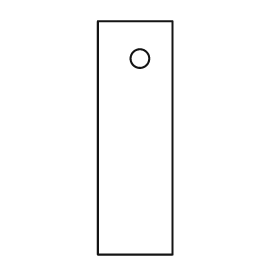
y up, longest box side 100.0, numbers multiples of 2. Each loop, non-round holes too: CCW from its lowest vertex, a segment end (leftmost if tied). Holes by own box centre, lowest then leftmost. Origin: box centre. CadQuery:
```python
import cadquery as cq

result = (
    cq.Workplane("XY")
    .moveTo(-16.0, -50.0)
    .lineTo(16.0, -50.0)
    .lineTo(16.0, 50.0)
    .lineTo(-16.0, 50.0)
    .close()
    .moveTo(2.0, 34.0)
    .circle(4.0)
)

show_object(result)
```